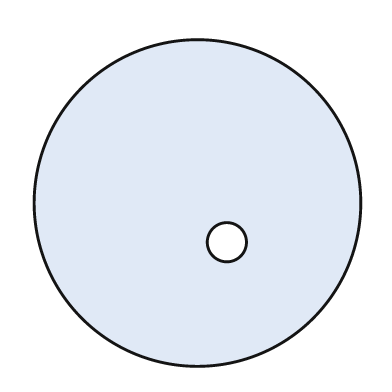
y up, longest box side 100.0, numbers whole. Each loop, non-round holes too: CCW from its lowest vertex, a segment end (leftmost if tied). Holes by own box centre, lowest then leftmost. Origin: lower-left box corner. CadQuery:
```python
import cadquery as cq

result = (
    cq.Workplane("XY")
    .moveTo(50.0, 50.0)
    .circle(50.0)
    .moveTo(59.0, 38.0)
    .circle(6.0)
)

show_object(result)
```